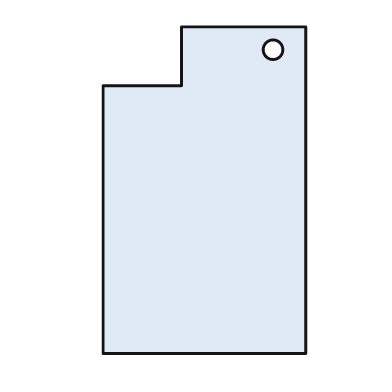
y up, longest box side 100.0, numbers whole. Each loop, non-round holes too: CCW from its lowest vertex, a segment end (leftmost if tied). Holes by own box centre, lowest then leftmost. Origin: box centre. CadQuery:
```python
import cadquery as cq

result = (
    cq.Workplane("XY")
    .moveTo(-31.0, -50.0)
    .lineTo(31.0, -50.0)
    .lineTo(31.0, 50.0)
    .lineTo(-7.0, 50.0)
    .lineTo(-7.0, 32.0)
    .lineTo(-31.0, 32.0)
    .close()
    .moveTo(21.0, 43.0)
    .circle(3.0)
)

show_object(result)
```